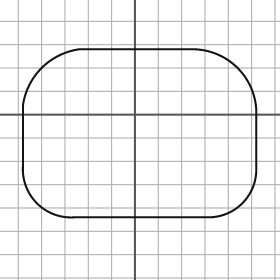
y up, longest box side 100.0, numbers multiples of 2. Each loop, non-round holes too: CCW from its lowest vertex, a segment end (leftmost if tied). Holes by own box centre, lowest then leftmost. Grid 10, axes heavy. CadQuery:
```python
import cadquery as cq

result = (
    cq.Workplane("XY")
    .moveTo(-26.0, -44.0)
    .lineTo(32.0, -44.0)
    .threePointArc((46.0, -38.0), (52.0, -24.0))
    .lineTo(52.0, 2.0)
    .threePointArc((44.0, 20.0), (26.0, 28.0))
    .lineTo(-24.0, 28.0)
    .threePointArc((-40.0, 20.0), (-48.0, 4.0))
    .lineTo(-48.0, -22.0)
    .threePointArc((-42.0, -38.0), (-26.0, -44.0))
    .close()
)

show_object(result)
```